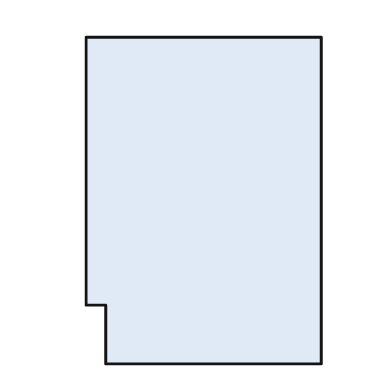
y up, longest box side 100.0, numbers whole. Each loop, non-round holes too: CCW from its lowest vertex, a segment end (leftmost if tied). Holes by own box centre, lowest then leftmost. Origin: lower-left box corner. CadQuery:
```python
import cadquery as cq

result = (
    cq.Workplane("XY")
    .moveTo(6.0, 0.0)
    .lineTo(72.0, 0.0)
    .lineTo(72.0, 100.0)
    .lineTo(0.0, 100.0)
    .lineTo(0.0, 18.0)
    .lineTo(6.0, 18.0)
    .close()
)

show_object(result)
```